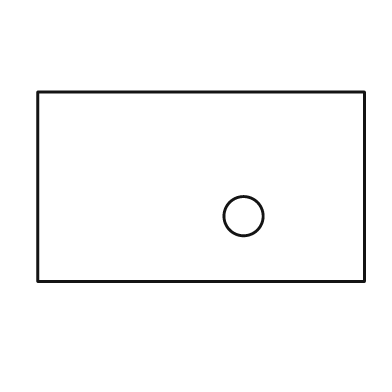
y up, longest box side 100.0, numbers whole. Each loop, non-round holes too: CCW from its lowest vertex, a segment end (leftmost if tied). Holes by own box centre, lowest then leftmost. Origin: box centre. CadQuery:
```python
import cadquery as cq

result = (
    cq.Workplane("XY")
    .moveTo(-50.0, -29.0)
    .lineTo(50.0, -29.0)
    .lineTo(50.0, 29.0)
    .lineTo(-50.0, 29.0)
    .close()
    .moveTo(13.0, -9.0)
    .circle(6.0)
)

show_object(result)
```